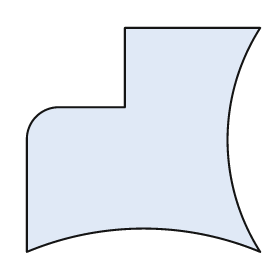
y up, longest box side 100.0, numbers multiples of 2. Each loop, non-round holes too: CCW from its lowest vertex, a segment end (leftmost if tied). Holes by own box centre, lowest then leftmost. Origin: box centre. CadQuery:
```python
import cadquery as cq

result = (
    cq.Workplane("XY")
    .moveTo(-50.0, -48.0)
    .threePointArc((0.0, -38.0), (50.0, -48.0))
    .threePointArc((36.0, 0.0), (50.0, 48.0))
    .lineTo(-8.0, 48.0)
    .lineTo(-8.0, 14.0)
    .lineTo(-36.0, 14.0)
    .threePointArc((-46.0, 10.0), (-50.0, 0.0))
    .close()
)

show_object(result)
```